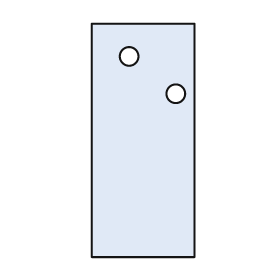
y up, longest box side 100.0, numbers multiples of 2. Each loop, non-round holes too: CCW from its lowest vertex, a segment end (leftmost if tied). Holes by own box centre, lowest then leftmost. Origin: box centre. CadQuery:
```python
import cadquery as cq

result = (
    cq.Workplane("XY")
    .moveTo(-22.0, -50.0)
    .lineTo(22.0, -50.0)
    .lineTo(22.0, 50.0)
    .lineTo(-22.0, 50.0)
    .close()
    .moveTo(14.0, 20.0)
    .circle(4.0)
    .moveTo(-6.0, 36.0)
    .circle(4.0)
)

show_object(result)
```